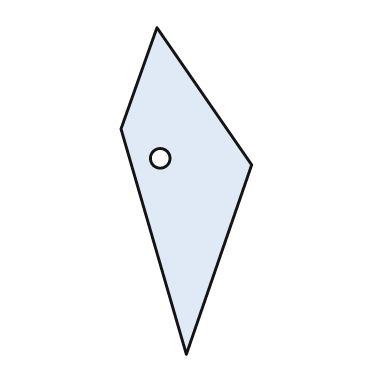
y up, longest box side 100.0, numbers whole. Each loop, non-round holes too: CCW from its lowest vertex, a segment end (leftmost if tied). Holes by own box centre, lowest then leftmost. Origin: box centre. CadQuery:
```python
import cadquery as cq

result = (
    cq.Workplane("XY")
    .moveTo(0.0, -50.0)
    .lineTo(20.0, 8.0)
    .lineTo(-9.0, 50.0)
    .lineTo(-20.0, 19.0)
    .close()
    .moveTo(-8.0, 10.0)
    .circle(3.0)
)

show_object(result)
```